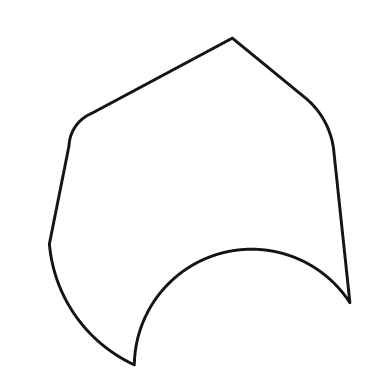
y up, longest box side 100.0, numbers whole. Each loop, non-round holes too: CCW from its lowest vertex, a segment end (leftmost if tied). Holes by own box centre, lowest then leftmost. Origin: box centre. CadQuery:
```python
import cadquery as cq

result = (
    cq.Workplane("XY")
    .moveTo(-20.0, -50.0)
    .threePointArc((6.0, -16.0), (46.0, -31.0))
    .lineTo(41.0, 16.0)
    .threePointArc((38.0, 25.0), (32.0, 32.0))
    .lineTo(10.0, 50.0)
    .lineTo(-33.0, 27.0)
    .threePointArc((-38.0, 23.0), (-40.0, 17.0))
    .lineTo(-46.0, -13.0)
    .threePointArc((-38.0, -35.0), (-20.0, -50.0))
    .close()
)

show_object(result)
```